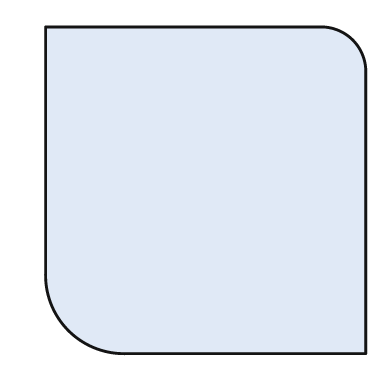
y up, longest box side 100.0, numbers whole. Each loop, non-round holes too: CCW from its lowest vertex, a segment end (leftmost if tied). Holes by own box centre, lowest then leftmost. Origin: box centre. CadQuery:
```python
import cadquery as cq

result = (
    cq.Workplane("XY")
    .moveTo(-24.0, -50.0)
    .lineTo(49.0, -50.0)
    .lineTo(49.0, 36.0)
    .threePointArc((45.0, 46.0), (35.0, 50.0))
    .lineTo(-49.0, 50.0)
    .lineTo(-49.0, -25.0)
    .threePointArc((-42.0, -43.0), (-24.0, -50.0))
    .close()
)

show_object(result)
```